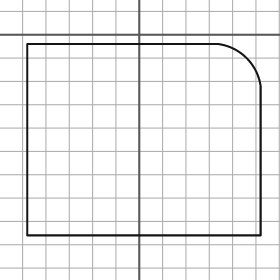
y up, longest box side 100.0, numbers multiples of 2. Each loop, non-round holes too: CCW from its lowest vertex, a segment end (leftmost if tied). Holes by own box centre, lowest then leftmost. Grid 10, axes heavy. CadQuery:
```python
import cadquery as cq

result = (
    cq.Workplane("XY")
    .moveTo(-48.0, -86.0)
    .lineTo(52.0, -86.0)
    .lineTo(52.0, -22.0)
    .threePointArc((46.0, -10.0), (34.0, -4.0))
    .lineTo(-48.0, -4.0)
    .close()
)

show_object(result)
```